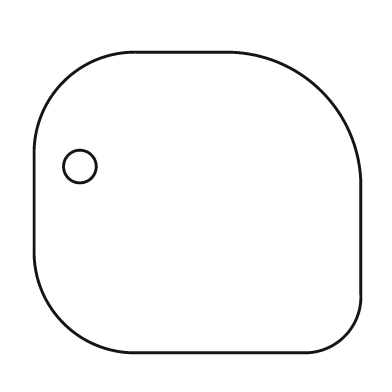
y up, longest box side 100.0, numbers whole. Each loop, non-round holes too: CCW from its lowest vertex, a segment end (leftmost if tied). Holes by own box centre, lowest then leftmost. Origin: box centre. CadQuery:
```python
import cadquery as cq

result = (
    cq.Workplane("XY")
    .moveTo(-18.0, -46.0)
    .lineTo(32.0, -46.0)
    .threePointArc((45.0, -41.0), (50.0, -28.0))
    .lineTo(50.0, 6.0)
    .threePointArc((38.0, 34.0), (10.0, 46.0))
    .lineTo(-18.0, 46.0)
    .threePointArc((-41.0, 37.0), (-50.0, 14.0))
    .lineTo(-50.0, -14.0)
    .threePointArc((-41.0, -37.0), (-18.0, -46.0))
    .close()
    .moveTo(-36.0, 11.0)
    .circle(5.0)
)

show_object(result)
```